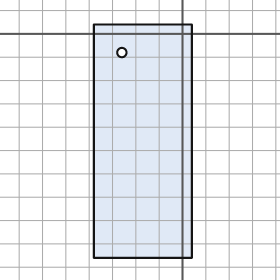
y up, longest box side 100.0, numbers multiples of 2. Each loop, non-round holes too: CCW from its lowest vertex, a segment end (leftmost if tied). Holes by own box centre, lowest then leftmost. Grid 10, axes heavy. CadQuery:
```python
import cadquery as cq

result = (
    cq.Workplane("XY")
    .moveTo(-38.0, -96.0)
    .lineTo(4.0, -96.0)
    .lineTo(4.0, 4.0)
    .lineTo(-38.0, 4.0)
    .close()
    .moveTo(-26.0, -8.0)
    .circle(2.0)
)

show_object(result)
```